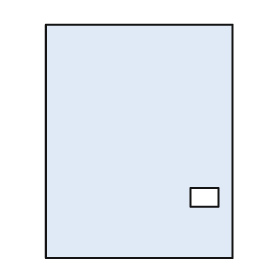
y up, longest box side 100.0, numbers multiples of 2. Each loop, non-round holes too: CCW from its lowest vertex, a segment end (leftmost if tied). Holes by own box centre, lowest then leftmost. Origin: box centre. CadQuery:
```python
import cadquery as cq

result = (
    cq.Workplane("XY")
    .moveTo(-40.0, -50.0)
    .lineTo(40.0, -50.0)
    .lineTo(40.0, 50.0)
    .lineTo(-40.0, 50.0)
    .close()
    .moveTo(22.0, -28.0)
    .lineTo(34.0, -28.0)
    .lineTo(34.0, -20.0)
    .lineTo(22.0, -20.0)
    .close()
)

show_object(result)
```